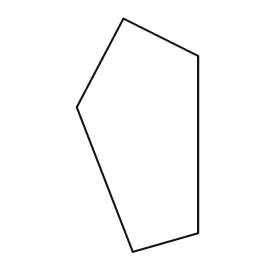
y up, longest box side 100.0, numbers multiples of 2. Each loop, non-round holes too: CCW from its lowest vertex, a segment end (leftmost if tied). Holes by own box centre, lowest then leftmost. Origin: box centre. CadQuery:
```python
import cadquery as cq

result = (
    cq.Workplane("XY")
    .moveTo(-2.0, -50.0)
    .lineTo(26.0, -42.0)
    .lineTo(26.0, 34.0)
    .lineTo(-6.0, 50.0)
    .lineTo(-26.0, 12.0)
    .close()
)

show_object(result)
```